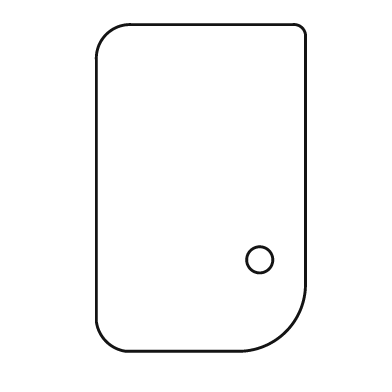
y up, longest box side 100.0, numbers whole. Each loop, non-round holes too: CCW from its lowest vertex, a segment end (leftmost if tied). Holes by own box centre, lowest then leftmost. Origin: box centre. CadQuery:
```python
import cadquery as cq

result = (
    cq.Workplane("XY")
    .moveTo(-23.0, -50.0)
    .lineTo(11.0, -50.0)
    .threePointArc((26.0, -44.0), (32.0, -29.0))
    .lineTo(32.0, 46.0)
    .threePointArc((31.0, 49.0), (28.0, 50.0))
    .lineTo(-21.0, 50.0)
    .threePointArc((-29.0, 47.0), (-32.0, 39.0))
    .lineTo(-32.0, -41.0)
    .threePointArc((-29.0, -47.0), (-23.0, -50.0))
    .close()
    .moveTo(18.0, -22.0)
    .circle(4.0)
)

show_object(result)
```